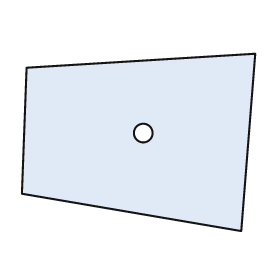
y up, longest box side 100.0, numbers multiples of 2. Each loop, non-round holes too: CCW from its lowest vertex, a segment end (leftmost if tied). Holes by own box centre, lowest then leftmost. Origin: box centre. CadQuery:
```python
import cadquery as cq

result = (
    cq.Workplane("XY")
    .moveTo(44.0, -38.0)
    .lineTo(50.0, 38.0)
    .lineTo(-48.0, 32.0)
    .lineTo(-50.0, -22.0)
    .close()
    .moveTo(2.0, 4.0)
    .circle(4.0)
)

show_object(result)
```